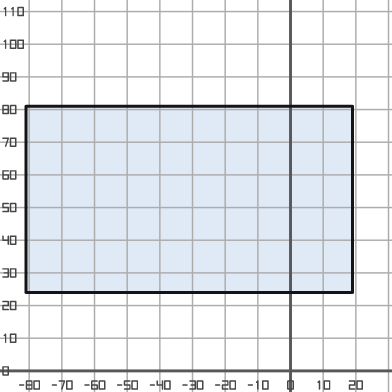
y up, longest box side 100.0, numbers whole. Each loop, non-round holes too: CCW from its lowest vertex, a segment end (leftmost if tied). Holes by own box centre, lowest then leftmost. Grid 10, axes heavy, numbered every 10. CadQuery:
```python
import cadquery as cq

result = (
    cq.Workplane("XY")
    .moveTo(-81.0, 24.0)
    .lineTo(19.0, 24.0)
    .lineTo(19.0, 81.0)
    .lineTo(-81.0, 81.0)
    .close()
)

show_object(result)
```